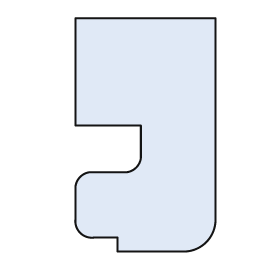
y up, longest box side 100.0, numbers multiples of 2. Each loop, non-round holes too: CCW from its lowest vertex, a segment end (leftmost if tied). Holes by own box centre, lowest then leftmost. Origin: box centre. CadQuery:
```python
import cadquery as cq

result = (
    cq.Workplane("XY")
    .moveTo(-12.0, -50.0)
    .lineTo(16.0, -50.0)
    .threePointArc((26.0, -46.0), (30.0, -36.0))
    .lineTo(30.0, 50.0)
    .lineTo(-30.0, 50.0)
    .lineTo(-30.0, 4.0)
    .lineTo(-2.0, 4.0)
    .lineTo(-2.0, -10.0)
    .threePointArc((-4.0, -14.0), (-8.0, -16.0))
    .lineTo(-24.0, -16.0)
    .threePointArc((-28.0, -18.0), (-30.0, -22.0))
    .lineTo(-30.0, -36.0)
    .threePointArc((-28.0, -42.0), (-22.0, -44.0))
    .lineTo(-12.0, -44.0)
    .close()
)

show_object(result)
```